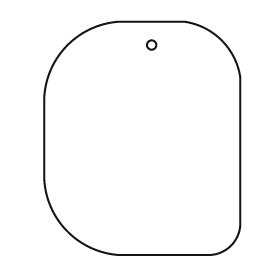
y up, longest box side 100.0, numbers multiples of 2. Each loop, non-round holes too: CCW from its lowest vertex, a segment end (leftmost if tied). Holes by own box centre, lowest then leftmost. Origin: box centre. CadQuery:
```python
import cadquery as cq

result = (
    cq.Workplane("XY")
    .moveTo(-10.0, -50.0)
    .lineTo(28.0, -50.0)
    .threePointArc((38.0, -46.0), (42.0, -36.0))
    .lineTo(42.0, 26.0)
    .threePointArc((34.0, 42.0), (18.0, 50.0))
    .lineTo(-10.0, 50.0)
    .threePointArc((-32.0, 40.0), (-42.0, 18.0))
    .lineTo(-42.0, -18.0)
    .threePointArc((-32.0, -40.0), (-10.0, -50.0))
    .close()
    .moveTo(4.0, 40.0)
    .circle(2.0)
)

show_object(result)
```